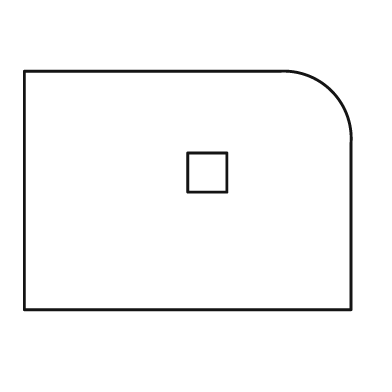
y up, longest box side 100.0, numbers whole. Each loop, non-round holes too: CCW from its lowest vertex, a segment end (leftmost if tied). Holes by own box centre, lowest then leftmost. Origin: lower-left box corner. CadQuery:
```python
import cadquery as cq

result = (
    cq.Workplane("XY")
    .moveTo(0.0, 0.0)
    .lineTo(100.0, 0.0)
    .lineTo(100.0, 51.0)
    .threePointArc((94.0, 67.0), (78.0, 73.0))
    .lineTo(0.0, 73.0)
    .close()
    .moveTo(50.0, 36.0)
    .lineTo(62.0, 36.0)
    .lineTo(62.0, 48.0)
    .lineTo(50.0, 48.0)
    .close()
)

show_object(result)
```